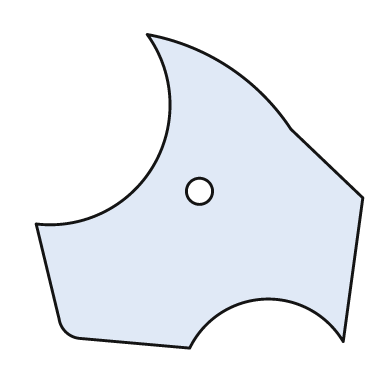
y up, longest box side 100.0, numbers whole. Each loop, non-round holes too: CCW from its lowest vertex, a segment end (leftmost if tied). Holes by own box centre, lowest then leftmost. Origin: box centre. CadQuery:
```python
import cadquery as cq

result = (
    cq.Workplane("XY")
    .moveTo(-3.0, -48.0)
    .threePointArc((20.0, -33.0), (44.0, -46.0))
    .lineTo(50.0, -2.0)
    .lineTo(28.0, 19.0)
    .threePointArc((9.0, 38.0), (-16.0, 48.0))
    .threePointArc((-14.0, 8.0), (-50.0, -10.0))
    .lineTo(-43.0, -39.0)
    .threePointArc((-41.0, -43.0), (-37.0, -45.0))
    .close()
    .moveTo(0.0, 0.0)
    .circle(4.0)
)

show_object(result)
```